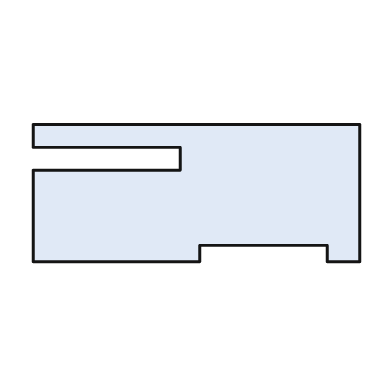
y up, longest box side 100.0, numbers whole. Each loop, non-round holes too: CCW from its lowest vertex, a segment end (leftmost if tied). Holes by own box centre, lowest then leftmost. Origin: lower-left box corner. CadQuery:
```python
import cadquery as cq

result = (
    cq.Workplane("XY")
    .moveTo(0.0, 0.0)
    .lineTo(51.0, 0.0)
    .lineTo(51.0, 5.0)
    .lineTo(90.0, 5.0)
    .lineTo(90.0, 0.0)
    .lineTo(100.0, 0.0)
    .lineTo(100.0, 42.0)
    .lineTo(0.0, 42.0)
    .lineTo(0.0, 35.0)
    .lineTo(45.0, 35.0)
    .lineTo(45.0, 28.0)
    .lineTo(0.0, 28.0)
    .close()
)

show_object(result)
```